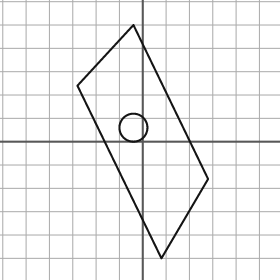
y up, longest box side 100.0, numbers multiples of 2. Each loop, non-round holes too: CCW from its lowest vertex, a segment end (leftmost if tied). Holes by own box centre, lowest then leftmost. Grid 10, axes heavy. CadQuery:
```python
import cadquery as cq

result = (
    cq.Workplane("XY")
    .moveTo(8.0, -50.0)
    .lineTo(28.0, -16.0)
    .lineTo(-4.0, 50.0)
    .lineTo(-28.0, 24.0)
    .close()
    .moveTo(-4.0, 6.0)
    .circle(6.0)
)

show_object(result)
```